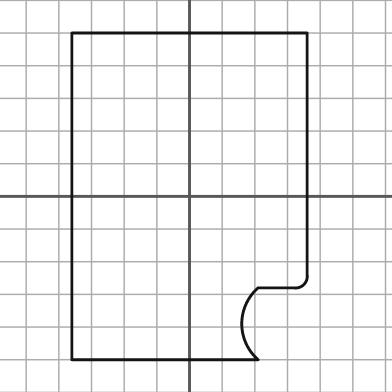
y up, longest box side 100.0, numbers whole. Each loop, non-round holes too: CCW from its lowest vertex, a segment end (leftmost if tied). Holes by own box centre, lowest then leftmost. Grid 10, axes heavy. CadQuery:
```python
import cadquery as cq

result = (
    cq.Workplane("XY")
    .moveTo(-36.0, -50.0)
    .lineTo(21.0, -50.0)
    .threePointArc((16.0, -39.0), (21.0, -28.0))
    .lineTo(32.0, -28.0)
    .threePointArc((35.0, -27.0), (36.0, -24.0))
    .lineTo(36.0, 50.0)
    .lineTo(-36.0, 50.0)
    .close()
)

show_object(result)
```